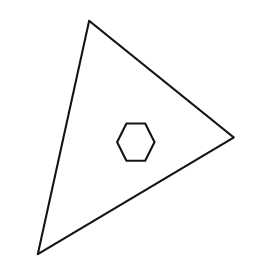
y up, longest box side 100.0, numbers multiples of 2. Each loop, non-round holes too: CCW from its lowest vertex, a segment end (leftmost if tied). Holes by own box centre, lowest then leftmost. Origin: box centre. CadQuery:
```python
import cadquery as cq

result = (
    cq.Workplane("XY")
    .moveTo(-42.0, -50.0)
    .lineTo(42.0, 0.0)
    .lineTo(-20.0, 50.0)
    .close()
    .moveTo(-4.0, -10.0)
    .lineTo(4.0, -10.0)
    .lineTo(8.0, -2.0)
    .lineTo(4.0, 6.0)
    .lineTo(-4.0, 6.0)
    .lineTo(-8.0, -2.0)
    .close()
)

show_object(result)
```